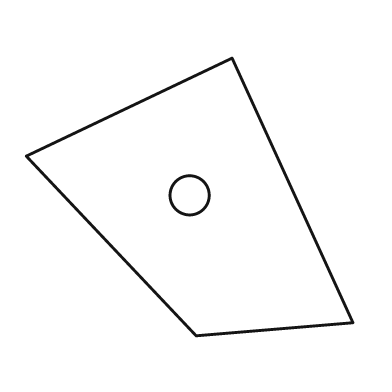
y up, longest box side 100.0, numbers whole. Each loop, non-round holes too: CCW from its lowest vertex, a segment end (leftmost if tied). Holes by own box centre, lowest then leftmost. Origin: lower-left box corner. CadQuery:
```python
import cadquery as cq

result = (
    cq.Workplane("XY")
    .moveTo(52.0, 0.0)
    .lineTo(100.0, 4.0)
    .lineTo(63.0, 85.0)
    .lineTo(0.0, 55.0)
    .close()
    .moveTo(50.0, 43.0)
    .circle(6.0)
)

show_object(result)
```